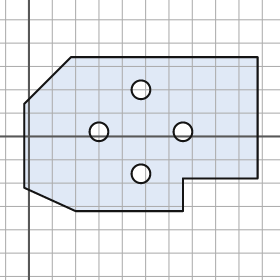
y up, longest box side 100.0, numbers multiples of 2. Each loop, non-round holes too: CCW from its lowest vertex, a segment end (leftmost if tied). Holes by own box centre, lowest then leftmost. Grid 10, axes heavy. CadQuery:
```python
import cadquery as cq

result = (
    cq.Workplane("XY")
    .moveTo(20.0, -32.0)
    .lineTo(66.0, -32.0)
    .lineTo(66.0, -18.0)
    .lineTo(98.0, -18.0)
    .lineTo(98.0, 34.0)
    .lineTo(18.0, 34.0)
    .lineTo(-2.0, 14.0)
    .lineTo(-2.0, -22.0)
    .close()
    .moveTo(48.0, -16.0)
    .circle(4.0)
    .moveTo(30.0, 2.0)
    .circle(4.0)
    .moveTo(66.0, 2.0)
    .circle(4.0)
    .moveTo(48.0, 20.0)
    .circle(4.0)
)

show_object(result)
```